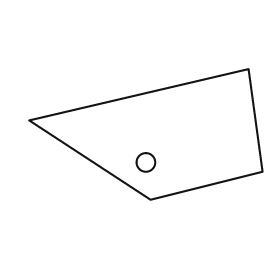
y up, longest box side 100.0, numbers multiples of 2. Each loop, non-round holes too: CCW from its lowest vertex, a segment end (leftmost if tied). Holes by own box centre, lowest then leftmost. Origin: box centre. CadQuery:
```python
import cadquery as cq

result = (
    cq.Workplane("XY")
    .moveTo(2.0, -28.0)
    .lineTo(50.0, -16.0)
    .lineTo(44.0, 28.0)
    .lineTo(-50.0, 6.0)
    .close()
    .moveTo(0.0, -12.0)
    .circle(4.0)
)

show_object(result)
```